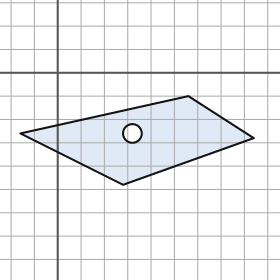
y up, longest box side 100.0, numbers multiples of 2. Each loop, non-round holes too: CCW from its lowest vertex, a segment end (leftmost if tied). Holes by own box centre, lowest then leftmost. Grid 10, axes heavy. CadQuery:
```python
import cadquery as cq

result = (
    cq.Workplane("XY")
    .moveTo(28.0, -48.0)
    .lineTo(84.0, -28.0)
    .lineTo(56.0, -10.0)
    .lineTo(-16.0, -26.0)
    .close()
    .moveTo(32.0, -26.0)
    .circle(4.0)
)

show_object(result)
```